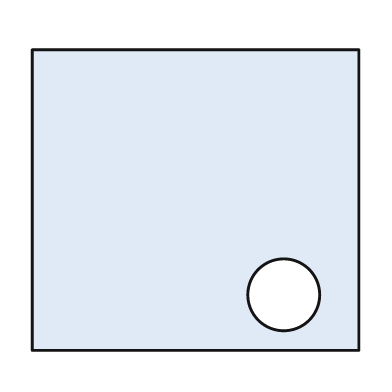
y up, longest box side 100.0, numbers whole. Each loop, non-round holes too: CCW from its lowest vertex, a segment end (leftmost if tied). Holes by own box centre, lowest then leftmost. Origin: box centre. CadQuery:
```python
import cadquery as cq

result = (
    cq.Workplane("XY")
    .moveTo(-50.0, -46.0)
    .lineTo(50.0, -46.0)
    .lineTo(50.0, 46.0)
    .lineTo(-50.0, 46.0)
    .close()
    .moveTo(27.0, -29.0)
    .circle(11.0)
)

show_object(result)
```